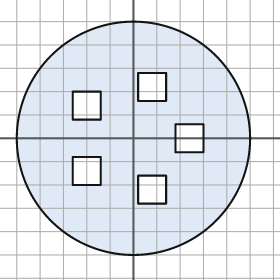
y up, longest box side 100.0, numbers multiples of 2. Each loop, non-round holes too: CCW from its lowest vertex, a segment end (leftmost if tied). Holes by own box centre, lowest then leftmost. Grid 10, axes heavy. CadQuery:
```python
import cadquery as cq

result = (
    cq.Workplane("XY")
    .moveTo(0.0, 0.0)
    .circle(50.0)
    .moveTo(2.0, -28.0)
    .lineTo(14.0, -28.0)
    .lineTo(14.0, -16.0)
    .lineTo(2.0, -16.0)
    .close()
    .moveTo(-26.0, -20.0)
    .lineTo(-14.0, -20.0)
    .lineTo(-14.0, -8.0)
    .lineTo(-26.0, -8.0)
    .close()
    .moveTo(18.0, -6.0)
    .lineTo(30.0, -6.0)
    .lineTo(30.0, 6.0)
    .lineTo(18.0, 6.0)
    .close()
    .moveTo(-26.0, 8.0)
    .lineTo(-14.0, 8.0)
    .lineTo(-14.0, 20.0)
    .lineTo(-26.0, 20.0)
    .close()
    .moveTo(2.0, 16.0)
    .lineTo(14.0, 16.0)
    .lineTo(14.0, 28.0)
    .lineTo(2.0, 28.0)
    .close()
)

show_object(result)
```